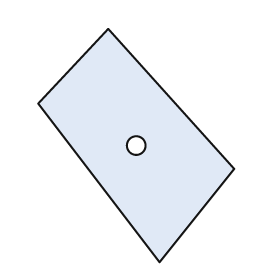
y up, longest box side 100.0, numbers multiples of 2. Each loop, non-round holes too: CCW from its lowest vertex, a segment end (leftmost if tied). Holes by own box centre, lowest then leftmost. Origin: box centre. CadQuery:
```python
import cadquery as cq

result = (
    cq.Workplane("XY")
    .moveTo(10.0, -50.0)
    .lineTo(42.0, -10.0)
    .lineTo(-12.0, 50.0)
    .lineTo(-42.0, 18.0)
    .close()
    .moveTo(0.0, 0.0)
    .circle(4.0)
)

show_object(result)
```